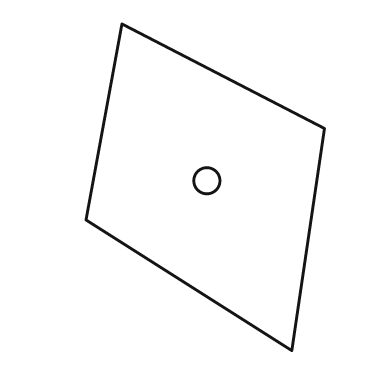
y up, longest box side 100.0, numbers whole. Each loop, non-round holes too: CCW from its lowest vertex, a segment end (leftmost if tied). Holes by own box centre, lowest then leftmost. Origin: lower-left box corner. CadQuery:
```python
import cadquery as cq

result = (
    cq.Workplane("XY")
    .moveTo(63.0, 0.0)
    .lineTo(73.0, 68.0)
    .lineTo(11.0, 100.0)
    .lineTo(0.0, 40.0)
    .close()
    .moveTo(37.0, 52.0)
    .circle(4.0)
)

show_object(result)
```